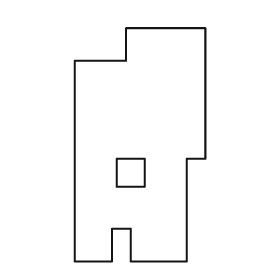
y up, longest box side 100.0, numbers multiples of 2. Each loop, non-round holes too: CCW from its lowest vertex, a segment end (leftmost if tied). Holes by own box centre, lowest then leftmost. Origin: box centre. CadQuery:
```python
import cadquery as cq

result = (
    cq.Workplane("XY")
    .moveTo(-28.0, -50.0)
    .lineTo(-12.0, -50.0)
    .lineTo(-12.0, -36.0)
    .lineTo(-4.0, -36.0)
    .lineTo(-4.0, -50.0)
    .lineTo(20.0, -50.0)
    .lineTo(20.0, -6.0)
    .lineTo(28.0, -6.0)
    .lineTo(28.0, 50.0)
    .lineTo(-6.0, 50.0)
    .lineTo(-6.0, 36.0)
    .lineTo(-28.0, 36.0)
    .close()
    .moveTo(-10.0, -18.0)
    .lineTo(2.0, -18.0)
    .lineTo(2.0, -6.0)
    .lineTo(-10.0, -6.0)
    .close()
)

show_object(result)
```